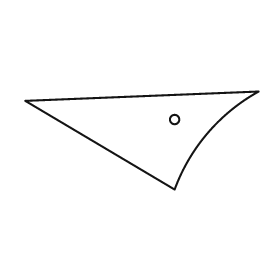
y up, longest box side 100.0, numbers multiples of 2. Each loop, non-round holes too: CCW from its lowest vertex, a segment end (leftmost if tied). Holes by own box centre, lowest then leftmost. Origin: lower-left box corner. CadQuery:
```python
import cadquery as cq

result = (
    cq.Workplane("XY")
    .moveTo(64.0, 0.0)
    .threePointArc((78.0, 24.0), (100.0, 42.0))
    .lineTo(0.0, 38.0)
    .close()
    .moveTo(64.0, 30.0)
    .circle(2.0)
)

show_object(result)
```